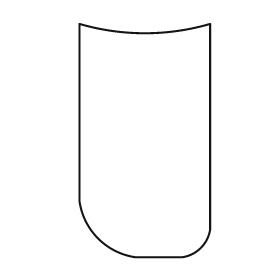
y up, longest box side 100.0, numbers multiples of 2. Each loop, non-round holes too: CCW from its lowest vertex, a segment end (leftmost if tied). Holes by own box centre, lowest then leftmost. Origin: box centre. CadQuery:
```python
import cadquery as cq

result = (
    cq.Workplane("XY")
    .moveTo(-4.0, -50.0)
    .lineTo(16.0, -50.0)
    .threePointArc((24.0, -46.0), (28.0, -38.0))
    .lineTo(28.0, 50.0)
    .threePointArc((0.0, 46.0), (-28.0, 50.0))
    .lineTo(-28.0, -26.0)
    .threePointArc((-20.0, -42.0), (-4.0, -50.0))
    .close()
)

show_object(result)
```